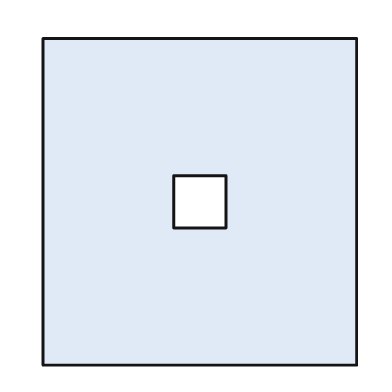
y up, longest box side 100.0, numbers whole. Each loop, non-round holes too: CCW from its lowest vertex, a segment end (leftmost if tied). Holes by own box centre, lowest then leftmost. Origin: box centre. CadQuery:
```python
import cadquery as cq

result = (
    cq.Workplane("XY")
    .moveTo(-48.0, -50.0)
    .lineTo(48.0, -50.0)
    .lineTo(48.0, 50.0)
    .lineTo(-48.0, 50.0)
    .close()
    .moveTo(-8.0, -8.0)
    .lineTo(8.0, -8.0)
    .lineTo(8.0, 8.0)
    .lineTo(-8.0, 8.0)
    .close()
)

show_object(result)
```